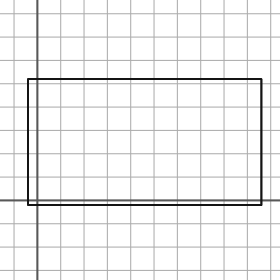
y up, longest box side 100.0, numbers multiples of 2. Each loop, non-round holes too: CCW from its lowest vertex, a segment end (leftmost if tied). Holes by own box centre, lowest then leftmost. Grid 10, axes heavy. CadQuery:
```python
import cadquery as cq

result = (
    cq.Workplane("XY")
    .moveTo(-4.0, -2.0)
    .lineTo(96.0, -2.0)
    .lineTo(96.0, 52.0)
    .lineTo(-4.0, 52.0)
    .close()
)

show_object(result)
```